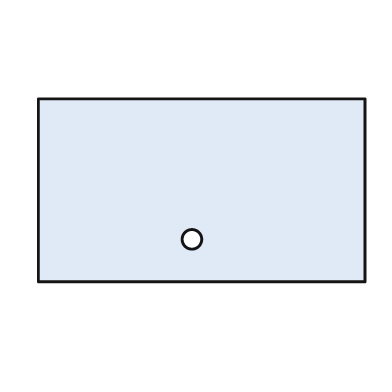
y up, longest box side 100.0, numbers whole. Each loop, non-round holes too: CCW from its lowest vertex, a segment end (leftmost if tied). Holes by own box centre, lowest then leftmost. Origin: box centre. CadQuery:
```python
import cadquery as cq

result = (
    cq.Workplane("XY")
    .moveTo(-50.0, -28.0)
    .lineTo(50.0, -28.0)
    .lineTo(50.0, 28.0)
    .lineTo(-50.0, 28.0)
    .close()
    .moveTo(-3.0, -15.0)
    .circle(3.0)
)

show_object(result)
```